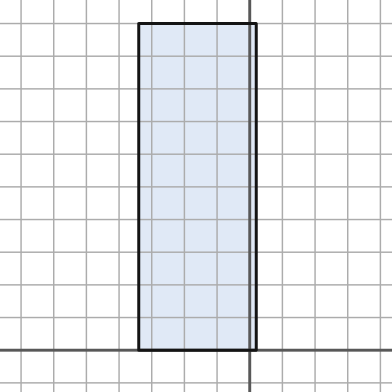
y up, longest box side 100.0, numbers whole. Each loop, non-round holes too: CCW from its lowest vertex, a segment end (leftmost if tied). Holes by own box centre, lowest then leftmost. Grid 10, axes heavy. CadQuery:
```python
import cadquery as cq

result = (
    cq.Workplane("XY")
    .moveTo(-34.0, 0.0)
    .lineTo(2.0, 0.0)
    .lineTo(2.0, 100.0)
    .lineTo(-34.0, 100.0)
    .close()
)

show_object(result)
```